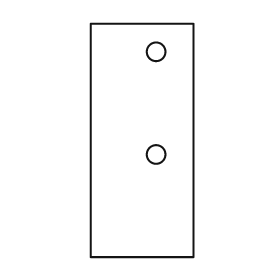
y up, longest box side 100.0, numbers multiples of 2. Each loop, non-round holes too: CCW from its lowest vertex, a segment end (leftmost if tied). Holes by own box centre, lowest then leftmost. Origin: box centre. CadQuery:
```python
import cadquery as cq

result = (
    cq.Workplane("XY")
    .moveTo(-22.0, -50.0)
    .lineTo(22.0, -50.0)
    .lineTo(22.0, 50.0)
    .lineTo(-22.0, 50.0)
    .close()
    .moveTo(6.0, -6.0)
    .circle(4.0)
    .moveTo(6.0, 38.0)
    .circle(4.0)
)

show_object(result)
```